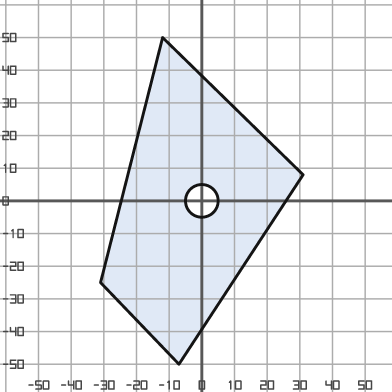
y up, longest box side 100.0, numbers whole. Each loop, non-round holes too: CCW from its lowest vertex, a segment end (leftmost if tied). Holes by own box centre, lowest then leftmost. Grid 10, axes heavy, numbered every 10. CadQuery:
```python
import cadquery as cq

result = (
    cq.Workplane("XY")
    .moveTo(-7.0, -50.0)
    .lineTo(31.0, 8.0)
    .lineTo(-12.0, 50.0)
    .lineTo(-31.0, -25.0)
    .close()
    .moveTo(0.0, 0.0)
    .circle(5.0)
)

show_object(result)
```